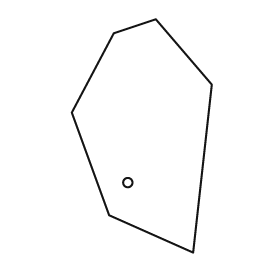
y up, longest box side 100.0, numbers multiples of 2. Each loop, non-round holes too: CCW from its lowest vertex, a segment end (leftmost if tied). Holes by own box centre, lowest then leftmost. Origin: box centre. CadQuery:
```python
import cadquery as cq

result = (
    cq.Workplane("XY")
    .moveTo(22.0, -50.0)
    .lineTo(30.0, 22.0)
    .lineTo(6.0, 50.0)
    .lineTo(-12.0, 44.0)
    .lineTo(-30.0, 10.0)
    .lineTo(-14.0, -34.0)
    .close()
    .moveTo(-6.0, -20.0)
    .circle(2.0)
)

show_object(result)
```